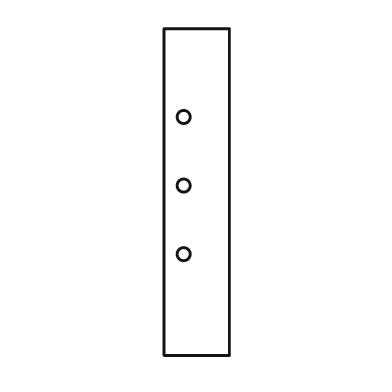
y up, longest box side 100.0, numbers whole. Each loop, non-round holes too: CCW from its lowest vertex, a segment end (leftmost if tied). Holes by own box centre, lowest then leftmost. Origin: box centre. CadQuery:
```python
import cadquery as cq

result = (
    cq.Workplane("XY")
    .moveTo(-10.0, -50.0)
    .lineTo(10.0, -50.0)
    .lineTo(10.0, 50.0)
    .lineTo(-10.0, 50.0)
    .close()
    .moveTo(-4.0, -19.0)
    .circle(2.0)
    .moveTo(-4.0, 2.0)
    .circle(2.0)
    .moveTo(-4.0, 23.0)
    .circle(2.0)
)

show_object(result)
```